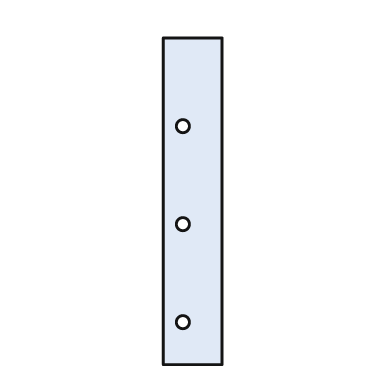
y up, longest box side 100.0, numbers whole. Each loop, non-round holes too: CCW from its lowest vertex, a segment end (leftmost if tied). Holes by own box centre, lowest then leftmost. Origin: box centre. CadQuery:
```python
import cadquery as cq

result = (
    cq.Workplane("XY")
    .moveTo(-9.0, -50.0)
    .lineTo(9.0, -50.0)
    .lineTo(9.0, 50.0)
    .lineTo(-9.0, 50.0)
    .close()
    .moveTo(-3.0, -37.0)
    .circle(2.0)
    .moveTo(-3.0, -7.0)
    .circle(2.0)
    .moveTo(-3.0, 23.0)
    .circle(2.0)
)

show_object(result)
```